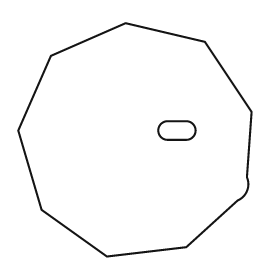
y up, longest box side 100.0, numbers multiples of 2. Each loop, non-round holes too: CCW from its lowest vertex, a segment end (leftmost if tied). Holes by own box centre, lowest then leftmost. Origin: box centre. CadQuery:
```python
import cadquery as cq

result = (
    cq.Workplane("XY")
    .moveTo(-12.0, -50.0)
    .lineTo(22.0, -46.0)
    .lineTo(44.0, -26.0)
    .threePointArc((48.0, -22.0), (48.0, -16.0))
    .lineTo(50.0, 12.0)
    .lineTo(30.0, 42.0)
    .lineTo(-4.0, 50.0)
    .lineTo(-36.0, 36.0)
    .lineTo(-50.0, 4.0)
    .lineTo(-40.0, -30.0)
    .close()
    .moveTo(14.0, 0.0)
    .lineTo(22.0, 0.0)
    .threePointArc((26.0, 4.0), (22.0, 8.0))
    .lineTo(14.0, 8.0)
    .threePointArc((10.0, 4.0), (14.0, 0.0))
    .close()
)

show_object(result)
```